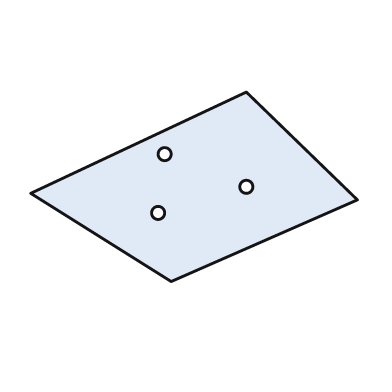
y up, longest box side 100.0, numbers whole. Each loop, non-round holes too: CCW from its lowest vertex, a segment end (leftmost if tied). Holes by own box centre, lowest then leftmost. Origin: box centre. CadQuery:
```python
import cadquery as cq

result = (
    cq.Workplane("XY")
    .moveTo(-7.0, -29.0)
    .lineTo(50.0, -4.0)
    .lineTo(16.0, 29.0)
    .lineTo(-50.0, -2.0)
    .close()
    .moveTo(-11.0, -8.0)
    .circle(2.0)
    .moveTo(16.0, 0.0)
    .circle(2.0)
    .moveTo(-9.0, 10.0)
    .circle(2.0)
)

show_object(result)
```